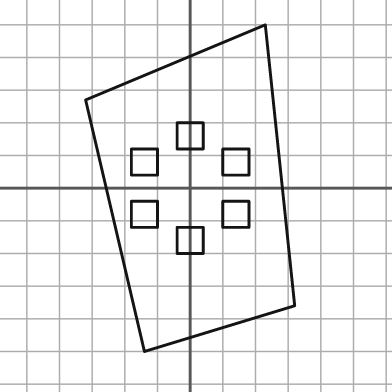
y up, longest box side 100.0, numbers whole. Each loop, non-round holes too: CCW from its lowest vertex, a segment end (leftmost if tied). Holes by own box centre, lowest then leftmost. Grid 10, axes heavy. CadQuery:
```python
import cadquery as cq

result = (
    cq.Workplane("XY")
    .moveTo(-14.0, -50.0)
    .lineTo(32.0, -36.0)
    .lineTo(23.0, 50.0)
    .lineTo(-32.0, 27.0)
    .close()
    .moveTo(-4.0, -20.0)
    .lineTo(4.0, -20.0)
    .lineTo(4.0, -12.0)
    .lineTo(-4.0, -12.0)
    .close()
    .moveTo(-18.0, -12.0)
    .lineTo(-10.0, -12.0)
    .lineTo(-10.0, -4.0)
    .lineTo(-18.0, -4.0)
    .close()
    .moveTo(10.0, -12.0)
    .lineTo(18.0, -12.0)
    .lineTo(18.0, -4.0)
    .lineTo(10.0, -4.0)
    .close()
    .moveTo(-18.0, 4.0)
    .lineTo(-10.0, 4.0)
    .lineTo(-10.0, 12.0)
    .lineTo(-18.0, 12.0)
    .close()
    .moveTo(10.0, 4.0)
    .lineTo(18.0, 4.0)
    .lineTo(18.0, 12.0)
    .lineTo(10.0, 12.0)
    .close()
    .moveTo(-4.0, 12.0)
    .lineTo(4.0, 12.0)
    .lineTo(4.0, 20.0)
    .lineTo(-4.0, 20.0)
    .close()
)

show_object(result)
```